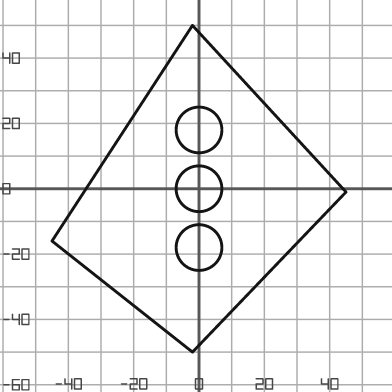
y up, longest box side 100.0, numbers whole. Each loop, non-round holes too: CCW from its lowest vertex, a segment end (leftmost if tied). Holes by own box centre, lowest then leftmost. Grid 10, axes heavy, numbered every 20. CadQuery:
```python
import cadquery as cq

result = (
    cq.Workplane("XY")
    .moveTo(-2.0, -50.0)
    .lineTo(45.0, -1.0)
    .lineTo(-2.0, 50.0)
    .lineTo(-45.0, -16.0)
    .close()
    .moveTo(0.0, -18.0)
    .circle(7.0)
    .moveTo(0.0, 0.0)
    .circle(7.0)
    .moveTo(0.0, 18.0)
    .circle(7.0)
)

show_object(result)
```